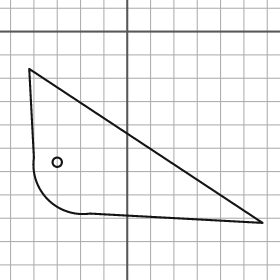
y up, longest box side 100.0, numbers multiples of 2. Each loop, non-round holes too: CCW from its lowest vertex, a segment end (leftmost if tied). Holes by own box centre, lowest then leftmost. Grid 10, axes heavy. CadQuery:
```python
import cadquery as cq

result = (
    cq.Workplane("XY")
    .moveTo(58.0, -82.0)
    .lineTo(-42.0, -16.0)
    .lineTo(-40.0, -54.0)
    .threePointArc((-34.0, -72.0), (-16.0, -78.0))
    .close()
    .moveTo(-30.0, -56.0)
    .circle(2.0)
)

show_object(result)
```